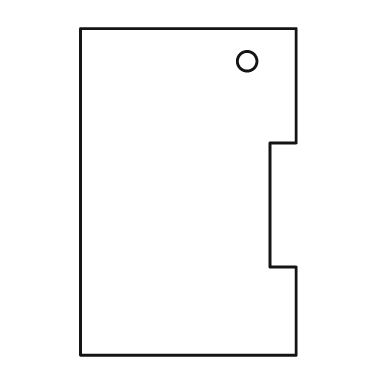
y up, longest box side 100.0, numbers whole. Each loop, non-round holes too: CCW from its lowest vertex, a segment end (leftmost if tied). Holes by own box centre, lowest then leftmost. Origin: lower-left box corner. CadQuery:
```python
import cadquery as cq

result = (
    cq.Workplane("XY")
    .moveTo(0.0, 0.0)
    .lineTo(66.0, 0.0)
    .lineTo(66.0, 27.0)
    .lineTo(58.0, 27.0)
    .lineTo(58.0, 65.0)
    .lineTo(66.0, 65.0)
    .lineTo(66.0, 100.0)
    .lineTo(0.0, 100.0)
    .close()
    .moveTo(51.0, 90.0)
    .circle(3.0)
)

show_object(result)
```